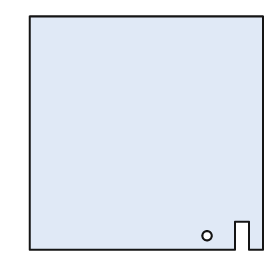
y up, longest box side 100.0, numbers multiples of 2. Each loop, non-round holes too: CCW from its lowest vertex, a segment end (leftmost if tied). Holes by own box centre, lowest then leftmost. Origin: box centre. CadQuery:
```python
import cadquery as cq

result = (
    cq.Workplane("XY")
    .moveTo(-50.0, -50.0)
    .lineTo(38.0, -50.0)
    .lineTo(38.0, -38.0)
    .lineTo(44.0, -38.0)
    .lineTo(44.0, -50.0)
    .lineTo(50.0, -50.0)
    .lineTo(50.0, 50.0)
    .lineTo(-50.0, 50.0)
    .close()
    .moveTo(26.0, -44.0)
    .circle(2.0)
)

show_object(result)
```